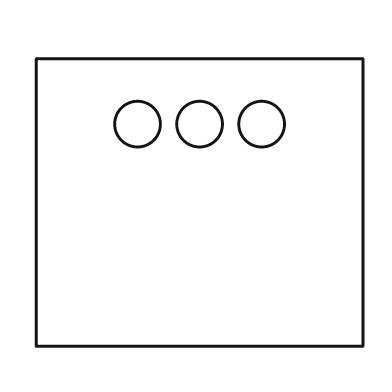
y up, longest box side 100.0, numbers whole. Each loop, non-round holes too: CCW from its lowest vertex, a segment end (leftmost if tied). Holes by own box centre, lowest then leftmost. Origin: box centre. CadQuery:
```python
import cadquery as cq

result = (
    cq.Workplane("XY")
    .moveTo(-50.0, -44.0)
    .lineTo(50.0, -44.0)
    .lineTo(50.0, 44.0)
    .lineTo(-50.0, 44.0)
    .close()
    .moveTo(-19.0, 24.0)
    .circle(7.0)
    .moveTo(0.0, 24.0)
    .circle(7.0)
    .moveTo(19.0, 24.0)
    .circle(7.0)
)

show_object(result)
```